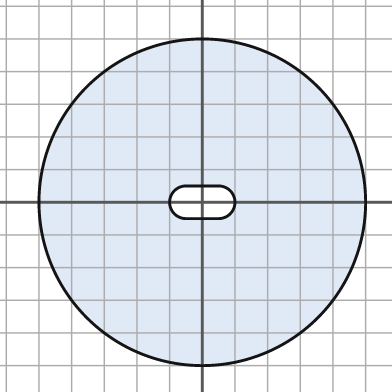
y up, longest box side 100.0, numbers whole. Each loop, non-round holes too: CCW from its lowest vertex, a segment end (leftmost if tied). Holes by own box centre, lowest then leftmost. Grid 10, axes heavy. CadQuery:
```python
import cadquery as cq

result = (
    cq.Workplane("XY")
    .moveTo(0.0, 0.0)
    .circle(50.0)
    .moveTo(-5.0, -5.0)
    .lineTo(5.0, -5.0)
    .threePointArc((10.0, 0.0), (5.0, 5.0))
    .lineTo(-5.0, 5.0)
    .threePointArc((-10.0, 0.0), (-5.0, -5.0))
    .close()
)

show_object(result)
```